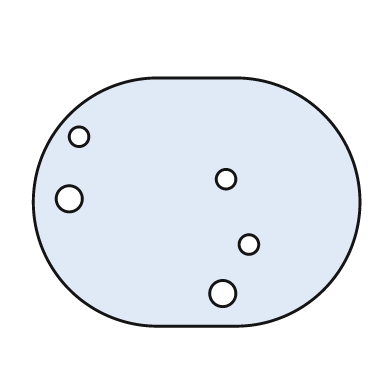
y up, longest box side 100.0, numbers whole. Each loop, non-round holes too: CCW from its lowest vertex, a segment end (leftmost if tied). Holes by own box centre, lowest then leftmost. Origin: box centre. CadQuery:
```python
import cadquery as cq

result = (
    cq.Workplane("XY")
    .moveTo(-12.0, -38.0)
    .lineTo(12.0, -38.0)
    .threePointArc((50.0, 0.0), (12.0, 38.0))
    .lineTo(-12.0, 38.0)
    .threePointArc((-50.0, 0.0), (-12.0, -38.0))
    .close()
    .moveTo(8.0, -28.0)
    .circle(4.0)
    .moveTo(16.0, -13.0)
    .circle(3.0)
    .moveTo(-39.0, 1.0)
    .circle(4.0)
    .moveTo(9.0, 7.0)
    .circle(3.0)
    .moveTo(-36.0, 20.0)
    .circle(3.0)
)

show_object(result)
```